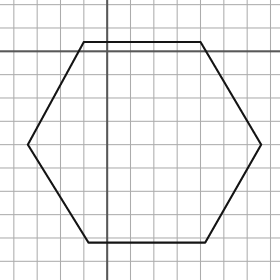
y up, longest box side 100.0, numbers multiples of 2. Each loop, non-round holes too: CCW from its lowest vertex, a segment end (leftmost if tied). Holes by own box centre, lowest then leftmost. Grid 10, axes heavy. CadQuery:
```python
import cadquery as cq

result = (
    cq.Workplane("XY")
    .moveTo(-8.0, -82.0)
    .lineTo(42.0, -82.0)
    .lineTo(66.0, -40.0)
    .lineTo(40.0, 4.0)
    .lineTo(-10.0, 4.0)
    .lineTo(-34.0, -40.0)
    .close()
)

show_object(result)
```